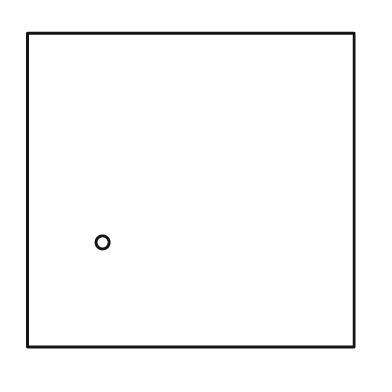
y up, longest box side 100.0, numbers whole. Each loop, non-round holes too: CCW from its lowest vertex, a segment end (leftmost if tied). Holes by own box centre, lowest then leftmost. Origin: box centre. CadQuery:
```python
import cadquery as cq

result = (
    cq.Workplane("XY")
    .moveTo(-50.0, -48.0)
    .lineTo(50.0, -48.0)
    .lineTo(50.0, 48.0)
    .lineTo(-50.0, 48.0)
    .close()
    .moveTo(-27.0, -16.0)
    .circle(2.0)
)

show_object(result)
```